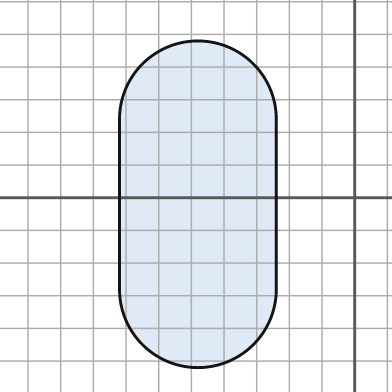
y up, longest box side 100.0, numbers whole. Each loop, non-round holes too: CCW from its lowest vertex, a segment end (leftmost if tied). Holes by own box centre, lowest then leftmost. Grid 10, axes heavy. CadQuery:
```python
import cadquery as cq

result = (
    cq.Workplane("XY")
    .moveTo(-72.0, -28.0)
    .threePointArc((-48.0, -52.0), (-24.0, -28.0))
    .lineTo(-24.0, 24.0)
    .threePointArc((-48.0, 48.0), (-72.0, 24.0))
    .close()
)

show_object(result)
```